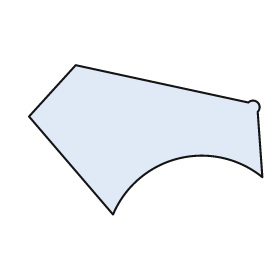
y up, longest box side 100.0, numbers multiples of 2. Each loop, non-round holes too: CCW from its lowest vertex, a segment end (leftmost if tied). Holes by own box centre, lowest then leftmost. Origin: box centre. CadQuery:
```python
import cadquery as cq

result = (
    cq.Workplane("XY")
    .moveTo(-14.0, -32.0)
    .threePointArc((14.0, -8.0), (50.0, -16.0))
    .lineTo(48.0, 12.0)
    .threePointArc((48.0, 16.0), (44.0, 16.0))
    .lineTo(-30.0, 32.0)
    .lineTo(-50.0, 10.0)
    .close()
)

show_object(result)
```